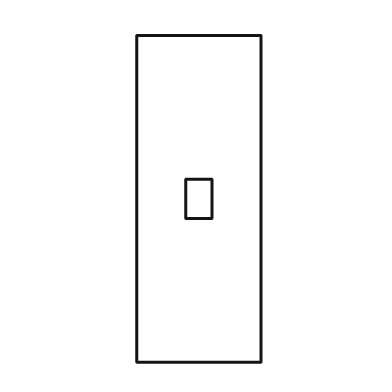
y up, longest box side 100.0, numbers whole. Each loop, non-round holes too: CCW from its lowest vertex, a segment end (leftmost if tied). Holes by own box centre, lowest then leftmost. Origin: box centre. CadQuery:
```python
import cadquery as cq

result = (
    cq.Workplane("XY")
    .moveTo(-19.0, -50.0)
    .lineTo(19.0, -50.0)
    .lineTo(19.0, 50.0)
    .lineTo(-19.0, 50.0)
    .close()
    .moveTo(-4.0, -6.0)
    .lineTo(4.0, -6.0)
    .lineTo(4.0, 6.0)
    .lineTo(-4.0, 6.0)
    .close()
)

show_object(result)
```